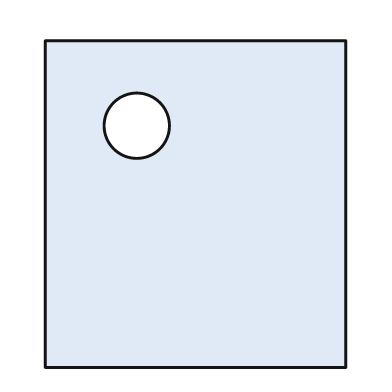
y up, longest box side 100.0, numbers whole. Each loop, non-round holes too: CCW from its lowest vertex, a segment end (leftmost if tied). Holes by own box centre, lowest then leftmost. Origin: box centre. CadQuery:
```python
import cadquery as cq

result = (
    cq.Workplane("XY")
    .moveTo(-46.0, -50.0)
    .lineTo(46.0, -50.0)
    .lineTo(46.0, 50.0)
    .lineTo(-46.0, 50.0)
    .close()
    .moveTo(-18.0, 24.0)
    .circle(10.0)
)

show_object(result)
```